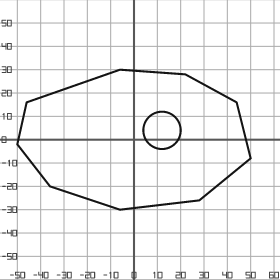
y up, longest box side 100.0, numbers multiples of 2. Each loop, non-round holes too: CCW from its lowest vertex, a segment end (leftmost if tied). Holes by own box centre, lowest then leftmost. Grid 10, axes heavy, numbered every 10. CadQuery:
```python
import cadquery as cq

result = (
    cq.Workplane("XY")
    .moveTo(-6.0, -30.0)
    .lineTo(28.0, -26.0)
    .lineTo(50.0, -8.0)
    .lineTo(44.0, 16.0)
    .lineTo(22.0, 28.0)
    .lineTo(-6.0, 30.0)
    .lineTo(-46.0, 16.0)
    .lineTo(-50.0, -2.0)
    .lineTo(-36.0, -20.0)
    .close()
    .moveTo(12.0, 4.0)
    .circle(8.0)
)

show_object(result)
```